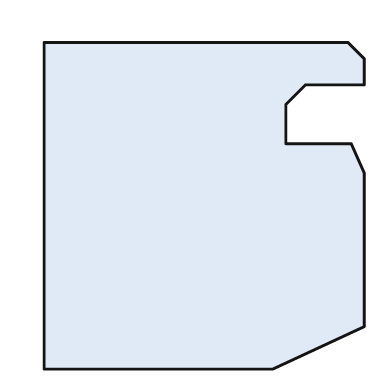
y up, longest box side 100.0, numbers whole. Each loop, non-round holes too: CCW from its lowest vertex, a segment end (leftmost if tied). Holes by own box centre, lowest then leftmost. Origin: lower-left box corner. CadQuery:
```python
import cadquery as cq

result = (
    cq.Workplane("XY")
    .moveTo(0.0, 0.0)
    .lineTo(70.0, 0.0)
    .lineTo(98.0, 13.0)
    .lineTo(98.0, 60.0)
    .lineTo(94.0, 69.0)
    .lineTo(74.0, 69.0)
    .lineTo(74.0, 81.0)
    .lineTo(80.0, 87.0)
    .lineTo(98.0, 87.0)
    .lineTo(98.0, 95.0)
    .lineTo(93.0, 100.0)
    .lineTo(0.0, 100.0)
    .close()
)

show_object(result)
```